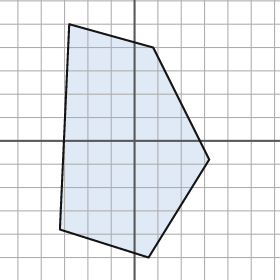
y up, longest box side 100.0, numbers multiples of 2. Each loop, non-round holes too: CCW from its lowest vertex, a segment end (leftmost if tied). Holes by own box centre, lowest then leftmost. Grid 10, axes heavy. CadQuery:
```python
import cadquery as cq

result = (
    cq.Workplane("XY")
    .moveTo(6.0, -50.0)
    .lineTo(32.0, -8.0)
    .lineTo(8.0, 40.0)
    .lineTo(-28.0, 50.0)
    .lineTo(-32.0, -38.0)
    .close()
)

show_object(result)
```